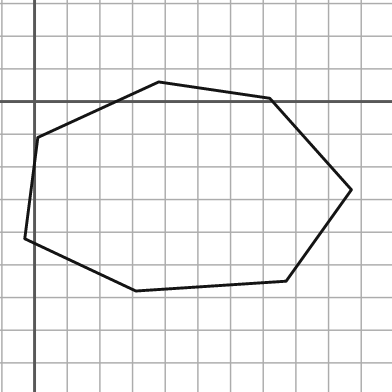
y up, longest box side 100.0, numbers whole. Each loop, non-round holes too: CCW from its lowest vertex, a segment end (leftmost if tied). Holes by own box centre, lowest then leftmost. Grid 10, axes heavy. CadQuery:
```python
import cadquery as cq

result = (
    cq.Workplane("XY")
    .moveTo(31.0, -58.0)
    .lineTo(77.0, -55.0)
    .lineTo(97.0, -27.0)
    .lineTo(72.0, 1.0)
    .lineTo(38.0, 6.0)
    .lineTo(1.0, -11.0)
    .lineTo(-3.0, -42.0)
    .close()
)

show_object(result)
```